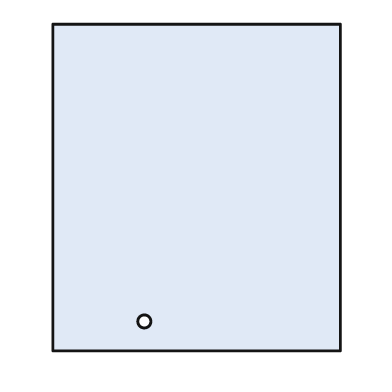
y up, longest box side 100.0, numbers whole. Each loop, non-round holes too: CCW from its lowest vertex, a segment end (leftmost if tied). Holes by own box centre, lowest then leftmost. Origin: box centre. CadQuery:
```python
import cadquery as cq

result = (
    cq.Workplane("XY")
    .moveTo(-44.0, -50.0)
    .lineTo(44.0, -50.0)
    .lineTo(44.0, 50.0)
    .lineTo(-44.0, 50.0)
    .close()
    .moveTo(-16.0, -41.0)
    .circle(2.0)
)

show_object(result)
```